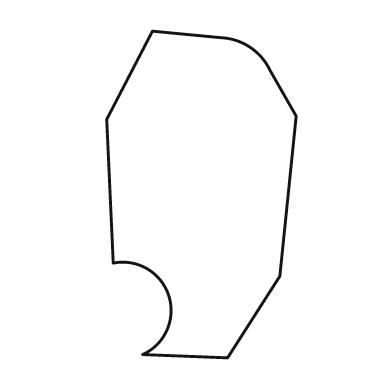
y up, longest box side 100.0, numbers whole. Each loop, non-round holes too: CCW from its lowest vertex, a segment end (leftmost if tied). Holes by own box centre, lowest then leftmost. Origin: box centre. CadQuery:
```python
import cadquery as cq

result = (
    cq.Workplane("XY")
    .moveTo(8.0, -50.0)
    .lineTo(24.0, -25.0)
    .lineTo(29.0, 24.0)
    .lineTo(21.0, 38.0)
    .threePointArc((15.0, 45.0), (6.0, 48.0))
    .lineTo(-15.0, 50.0)
    .lineTo(-29.0, 23.0)
    .lineTo(-27.0, -21.0)
    .threePointArc((-10.0, -31.0), (-18.0, -49.0))
    .close()
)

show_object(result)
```